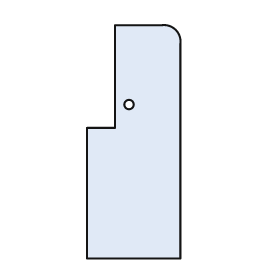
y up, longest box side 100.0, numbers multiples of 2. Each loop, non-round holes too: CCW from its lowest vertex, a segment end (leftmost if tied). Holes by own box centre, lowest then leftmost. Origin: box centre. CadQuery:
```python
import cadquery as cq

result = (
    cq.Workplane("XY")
    .moveTo(-20.0, -50.0)
    .lineTo(20.0, -50.0)
    .lineTo(20.0, 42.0)
    .threePointArc((18.0, 48.0), (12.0, 50.0))
    .lineTo(-8.0, 50.0)
    .lineTo(-8.0, 6.0)
    .lineTo(-20.0, 6.0)
    .close()
    .moveTo(-2.0, 16.0)
    .circle(2.0)
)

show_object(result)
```